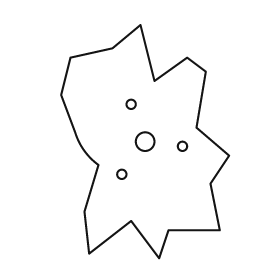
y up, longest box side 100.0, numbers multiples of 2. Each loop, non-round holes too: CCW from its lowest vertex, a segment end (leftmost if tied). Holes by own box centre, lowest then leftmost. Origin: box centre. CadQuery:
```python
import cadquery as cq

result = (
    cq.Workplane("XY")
    .moveTo(6.0, -50.0)
    .lineTo(10.0, -38.0)
    .lineTo(32.0, -38.0)
    .lineTo(28.0, -18.0)
    .lineTo(36.0, -6.0)
    .lineTo(22.0, 6.0)
    .lineTo(26.0, 30.0)
    .lineTo(18.0, 36.0)
    .lineTo(4.0, 26.0)
    .lineTo(-2.0, 50.0)
    .lineTo(-14.0, 40.0)
    .lineTo(-32.0, 36.0)
    .lineTo(-36.0, 20.0)
    .lineTo(-30.0, 4.0)
    .threePointArc((-26.0, -4.0), (-20.0, -10.0))
    .lineTo(-26.0, -30.0)
    .lineTo(-24.0, -48.0)
    .lineTo(-6.0, -34.0)
    .close()
    .moveTo(-10.0, -14.0)
    .circle(2.0)
    .moveTo(16.0, -2.0)
    .circle(2.0)
    .moveTo(0.0, 0.0)
    .circle(4.0)
    .moveTo(-6.0, 16.0)
    .circle(2.0)
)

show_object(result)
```